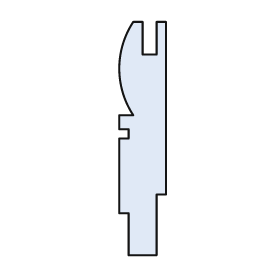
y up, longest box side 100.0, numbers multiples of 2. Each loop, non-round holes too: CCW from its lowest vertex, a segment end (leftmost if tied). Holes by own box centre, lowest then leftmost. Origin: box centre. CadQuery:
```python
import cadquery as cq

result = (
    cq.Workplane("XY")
    .moveTo(-6.0, -50.0)
    .lineTo(6.0, -50.0)
    .lineTo(6.0, -24.0)
    .lineTo(10.0, -24.0)
    .lineTo(10.0, 50.0)
    .lineTo(6.0, 50.0)
    .lineTo(6.0, 36.0)
    .lineTo(0.0, 36.0)
    .lineTo(0.0, 50.0)
    .lineTo(-4.0, 50.0)
    .threePointArc((-10.0, 30.0), (-4.0, 10.0))
    .lineTo(-10.0, 10.0)
    .lineTo(-10.0, 4.0)
    .lineTo(-6.0, 4.0)
    .lineTo(-6.0, 0.0)
    .lineTo(-10.0, 0.0)
    .lineTo(-10.0, -32.0)
    .lineTo(-6.0, -32.0)
    .close()
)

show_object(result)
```